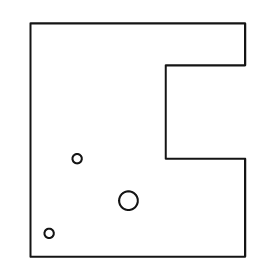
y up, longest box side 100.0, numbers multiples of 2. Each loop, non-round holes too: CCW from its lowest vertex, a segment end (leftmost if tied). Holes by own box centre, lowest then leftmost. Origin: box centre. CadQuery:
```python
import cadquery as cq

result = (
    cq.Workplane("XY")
    .moveTo(-46.0, -50.0)
    .lineTo(46.0, -50.0)
    .lineTo(46.0, -8.0)
    .lineTo(12.0, -8.0)
    .lineTo(12.0, 32.0)
    .lineTo(46.0, 32.0)
    .lineTo(46.0, 50.0)
    .lineTo(-46.0, 50.0)
    .close()
    .moveTo(-38.0, -40.0)
    .circle(2.0)
    .moveTo(-4.0, -26.0)
    .circle(4.0)
    .moveTo(-26.0, -8.0)
    .circle(2.0)
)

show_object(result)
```